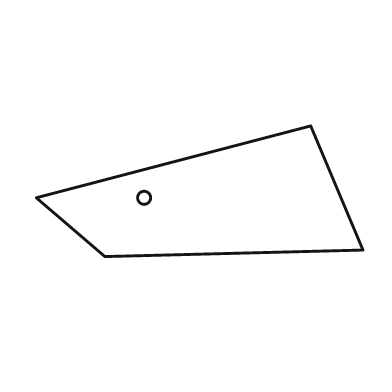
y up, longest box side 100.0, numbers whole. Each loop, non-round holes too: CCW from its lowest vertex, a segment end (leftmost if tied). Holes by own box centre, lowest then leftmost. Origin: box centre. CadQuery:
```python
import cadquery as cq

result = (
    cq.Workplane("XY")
    .moveTo(-29.0, -20.0)
    .lineTo(50.0, -18.0)
    .lineTo(34.0, 20.0)
    .lineTo(-50.0, -2.0)
    .close()
    .moveTo(-17.0, -2.0)
    .circle(2.0)
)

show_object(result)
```